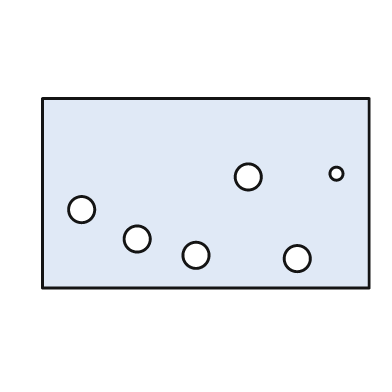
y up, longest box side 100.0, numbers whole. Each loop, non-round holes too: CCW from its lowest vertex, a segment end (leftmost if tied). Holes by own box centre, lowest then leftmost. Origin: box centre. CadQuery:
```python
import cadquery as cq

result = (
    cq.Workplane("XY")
    .moveTo(-50.0, -29.0)
    .lineTo(50.0, -29.0)
    .lineTo(50.0, 29.0)
    .lineTo(-50.0, 29.0)
    .close()
    .moveTo(28.0, -20.0)
    .circle(4.0)
    .moveTo(-3.0, -19.0)
    .circle(4.0)
    .moveTo(-21.0, -14.0)
    .circle(4.0)
    .moveTo(-38.0, -5.0)
    .circle(4.0)
    .moveTo(13.0, 5.0)
    .circle(4.0)
    .moveTo(40.0, 6.0)
    .circle(2.0)
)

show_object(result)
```